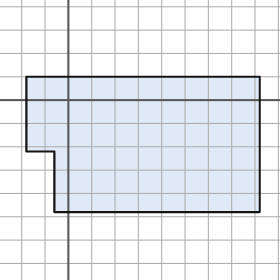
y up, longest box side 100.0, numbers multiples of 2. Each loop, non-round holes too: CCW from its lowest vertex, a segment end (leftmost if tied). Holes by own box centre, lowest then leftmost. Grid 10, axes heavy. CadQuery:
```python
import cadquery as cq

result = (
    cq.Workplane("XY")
    .moveTo(-6.0, -48.0)
    .lineTo(82.0, -48.0)
    .lineTo(82.0, 10.0)
    .lineTo(-18.0, 10.0)
    .lineTo(-18.0, -22.0)
    .lineTo(-6.0, -22.0)
    .close()
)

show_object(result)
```